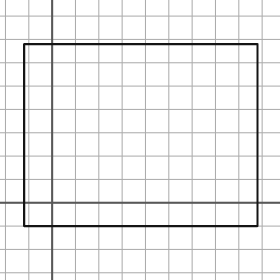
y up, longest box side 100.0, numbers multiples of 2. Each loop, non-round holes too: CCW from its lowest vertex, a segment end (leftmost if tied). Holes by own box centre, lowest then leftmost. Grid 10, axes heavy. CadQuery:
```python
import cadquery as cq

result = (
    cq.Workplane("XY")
    .moveTo(-12.0, -10.0)
    .lineTo(88.0, -10.0)
    .lineTo(88.0, 68.0)
    .lineTo(-12.0, 68.0)
    .close()
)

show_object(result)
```